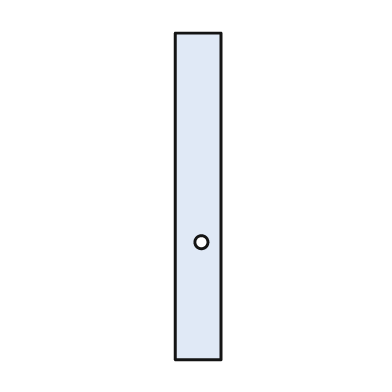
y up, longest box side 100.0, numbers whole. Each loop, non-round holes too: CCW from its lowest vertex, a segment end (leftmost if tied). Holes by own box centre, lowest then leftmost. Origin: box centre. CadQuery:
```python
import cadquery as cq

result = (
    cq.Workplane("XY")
    .moveTo(-7.0, -50.0)
    .lineTo(7.0, -50.0)
    .lineTo(7.0, 50.0)
    .lineTo(-7.0, 50.0)
    .close()
    .moveTo(1.0, -14.0)
    .circle(2.0)
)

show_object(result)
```